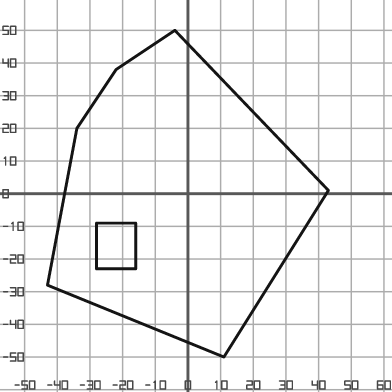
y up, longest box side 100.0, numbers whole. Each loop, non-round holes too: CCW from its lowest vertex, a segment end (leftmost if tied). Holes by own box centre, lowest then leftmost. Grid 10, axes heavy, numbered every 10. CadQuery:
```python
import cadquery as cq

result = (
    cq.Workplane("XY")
    .moveTo(11.0, -50.0)
    .lineTo(43.0, 1.0)
    .lineTo(-4.0, 50.0)
    .lineTo(-22.0, 38.0)
    .lineTo(-34.0, 20.0)
    .lineTo(-43.0, -28.0)
    .close()
    .moveTo(-28.0, -23.0)
    .lineTo(-16.0, -23.0)
    .lineTo(-16.0, -9.0)
    .lineTo(-28.0, -9.0)
    .close()
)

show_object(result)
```